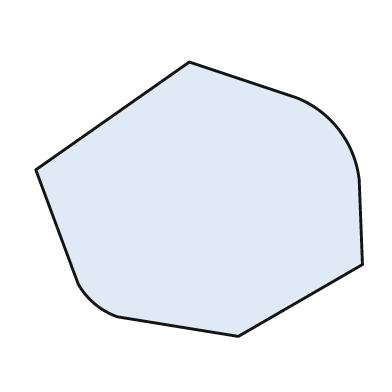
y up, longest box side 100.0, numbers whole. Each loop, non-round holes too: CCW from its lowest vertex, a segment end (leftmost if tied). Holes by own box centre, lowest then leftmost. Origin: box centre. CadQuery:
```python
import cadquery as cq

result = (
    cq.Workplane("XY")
    .moveTo(12.0, -42.0)
    .lineTo(50.0, -20.0)
    .lineTo(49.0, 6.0)
    .threePointArc((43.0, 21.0), (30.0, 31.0))
    .lineTo(-3.0, 42.0)
    .lineTo(-50.0, 9.0)
    .lineTo(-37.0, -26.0)
    .threePointArc((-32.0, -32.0), (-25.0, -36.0))
    .close()
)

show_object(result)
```